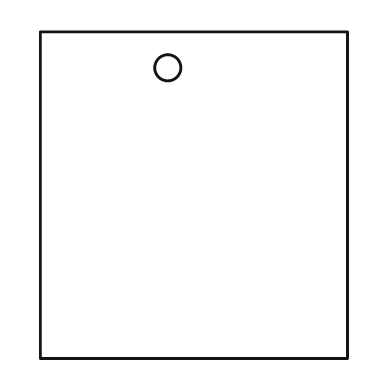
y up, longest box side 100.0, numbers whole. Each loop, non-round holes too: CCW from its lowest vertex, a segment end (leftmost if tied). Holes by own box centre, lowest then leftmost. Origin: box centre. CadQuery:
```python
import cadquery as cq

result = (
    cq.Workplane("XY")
    .moveTo(-47.0, -50.0)
    .lineTo(47.0, -50.0)
    .lineTo(47.0, 50.0)
    .lineTo(-47.0, 50.0)
    .close()
    .moveTo(-8.0, 39.0)
    .circle(4.0)
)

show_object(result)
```